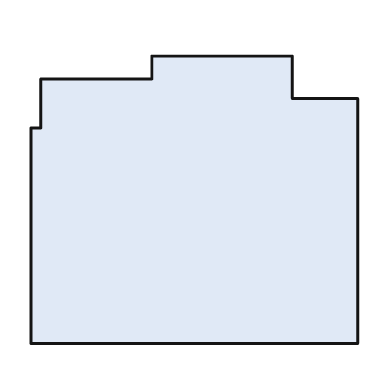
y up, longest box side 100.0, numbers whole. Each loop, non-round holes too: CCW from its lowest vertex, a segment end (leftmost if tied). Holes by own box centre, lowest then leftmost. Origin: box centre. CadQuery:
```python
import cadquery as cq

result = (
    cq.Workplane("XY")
    .moveTo(-50.0, -44.0)
    .lineTo(50.0, -44.0)
    .lineTo(50.0, 31.0)
    .lineTo(30.0, 31.0)
    .lineTo(30.0, 44.0)
    .lineTo(-13.0, 44.0)
    .lineTo(-13.0, 37.0)
    .lineTo(-47.0, 37.0)
    .lineTo(-47.0, 22.0)
    .lineTo(-50.0, 22.0)
    .close()
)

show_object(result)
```